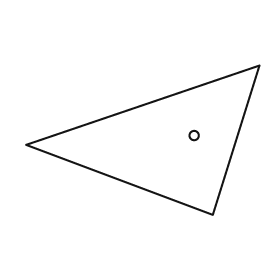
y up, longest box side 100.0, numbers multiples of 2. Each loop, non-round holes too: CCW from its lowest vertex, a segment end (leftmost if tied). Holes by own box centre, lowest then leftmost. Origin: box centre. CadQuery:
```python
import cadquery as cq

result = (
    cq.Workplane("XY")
    .moveTo(30.0, -32.0)
    .lineTo(50.0, 32.0)
    .lineTo(-50.0, -2.0)
    .close()
    .moveTo(22.0, 2.0)
    .circle(2.0)
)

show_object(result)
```